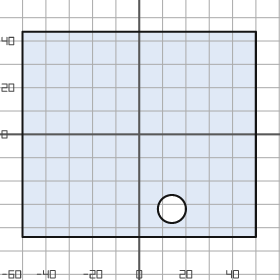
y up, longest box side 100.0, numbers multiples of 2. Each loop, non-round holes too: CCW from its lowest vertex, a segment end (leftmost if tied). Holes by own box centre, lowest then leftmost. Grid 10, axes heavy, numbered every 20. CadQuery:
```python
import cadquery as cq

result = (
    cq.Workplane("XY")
    .moveTo(-50.0, -44.0)
    .lineTo(50.0, -44.0)
    .lineTo(50.0, 44.0)
    .lineTo(-50.0, 44.0)
    .close()
    .moveTo(14.0, -32.0)
    .circle(6.0)
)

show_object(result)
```